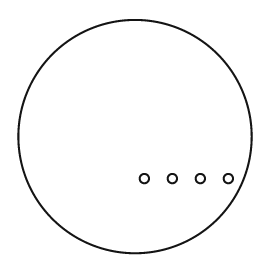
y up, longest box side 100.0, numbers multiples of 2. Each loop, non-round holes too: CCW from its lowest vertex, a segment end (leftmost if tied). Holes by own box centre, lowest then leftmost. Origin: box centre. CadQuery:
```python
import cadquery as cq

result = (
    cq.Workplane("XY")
    .moveTo(0.0, 0.0)
    .circle(50.0)
    .moveTo(4.0, -18.0)
    .circle(2.0)
    .moveTo(16.0, -18.0)
    .circle(2.0)
    .moveTo(28.0, -18.0)
    .circle(2.0)
    .moveTo(40.0, -18.0)
    .circle(2.0)
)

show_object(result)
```